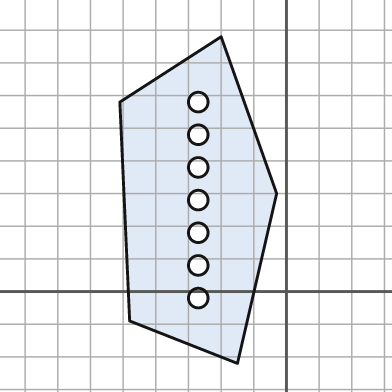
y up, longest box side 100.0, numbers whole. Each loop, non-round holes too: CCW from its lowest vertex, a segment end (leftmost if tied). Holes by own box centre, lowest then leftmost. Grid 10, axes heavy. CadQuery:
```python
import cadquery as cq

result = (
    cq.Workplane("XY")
    .moveTo(-15.0, -22.0)
    .lineTo(-3.0, 30.0)
    .lineTo(-20.0, 78.0)
    .lineTo(-51.0, 58.0)
    .lineTo(-48.0, -9.0)
    .close()
    .moveTo(-27.0, -2.0)
    .circle(3.0)
    .moveTo(-27.0, 8.0)
    .circle(3.0)
    .moveTo(-27.0, 18.0)
    .circle(3.0)
    .moveTo(-27.0, 28.0)
    .circle(3.0)
    .moveTo(-27.0, 38.0)
    .circle(3.0)
    .moveTo(-27.0, 48.0)
    .circle(3.0)
    .moveTo(-27.0, 58.0)
    .circle(3.0)
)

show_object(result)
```